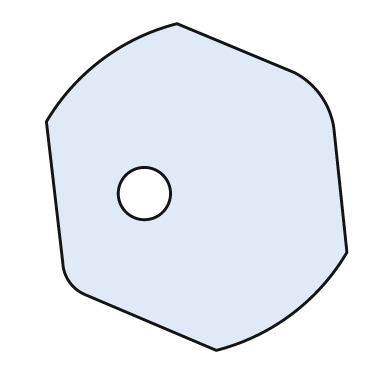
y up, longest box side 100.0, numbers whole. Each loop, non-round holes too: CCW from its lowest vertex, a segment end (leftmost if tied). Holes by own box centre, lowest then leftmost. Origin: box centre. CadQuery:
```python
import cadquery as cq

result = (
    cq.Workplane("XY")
    .moveTo(6.0, -50.0)
    .threePointArc((29.0, -39.0), (46.0, -20.0))
    .lineTo(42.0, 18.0)
    .threePointArc((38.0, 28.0), (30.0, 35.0))
    .lineTo(-6.0, 50.0)
    .threePointArc((-29.0, 39.0), (-46.0, 20.0))
    .lineTo(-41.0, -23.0)
    .threePointArc((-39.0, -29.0), (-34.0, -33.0))
    .close()
    .moveTo(-16.0, -2.0)
    .circle(8.0)
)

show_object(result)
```